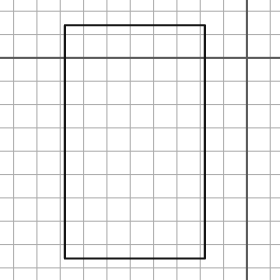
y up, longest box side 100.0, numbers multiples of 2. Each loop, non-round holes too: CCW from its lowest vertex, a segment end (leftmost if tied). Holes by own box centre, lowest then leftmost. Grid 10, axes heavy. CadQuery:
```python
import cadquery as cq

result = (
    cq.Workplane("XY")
    .moveTo(-78.0, -86.0)
    .lineTo(-18.0, -86.0)
    .lineTo(-18.0, 14.0)
    .lineTo(-78.0, 14.0)
    .close()
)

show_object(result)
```